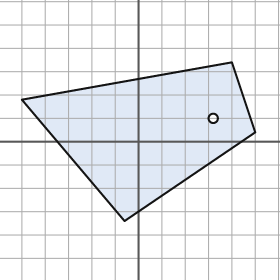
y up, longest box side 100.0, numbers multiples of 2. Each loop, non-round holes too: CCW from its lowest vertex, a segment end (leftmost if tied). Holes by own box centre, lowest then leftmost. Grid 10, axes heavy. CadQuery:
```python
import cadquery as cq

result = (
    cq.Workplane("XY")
    .moveTo(-6.0, -34.0)
    .lineTo(50.0, 4.0)
    .lineTo(40.0, 34.0)
    .lineTo(-50.0, 18.0)
    .close()
    .moveTo(32.0, 10.0)
    .circle(2.0)
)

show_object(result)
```